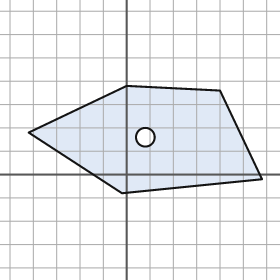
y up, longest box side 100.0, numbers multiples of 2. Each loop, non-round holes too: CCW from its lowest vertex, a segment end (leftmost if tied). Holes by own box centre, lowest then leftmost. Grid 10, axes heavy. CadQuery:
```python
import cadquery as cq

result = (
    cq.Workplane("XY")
    .moveTo(-2.0, -8.0)
    .lineTo(58.0, -2.0)
    .lineTo(40.0, 36.0)
    .lineTo(0.0, 38.0)
    .lineTo(-42.0, 18.0)
    .close()
    .moveTo(8.0, 16.0)
    .circle(4.0)
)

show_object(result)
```